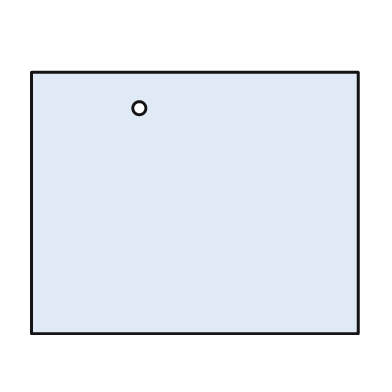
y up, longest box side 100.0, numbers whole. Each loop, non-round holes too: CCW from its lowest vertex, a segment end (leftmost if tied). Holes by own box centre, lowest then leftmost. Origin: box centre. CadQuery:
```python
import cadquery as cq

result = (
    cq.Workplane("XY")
    .moveTo(-50.0, -40.0)
    .lineTo(50.0, -40.0)
    .lineTo(50.0, 40.0)
    .lineTo(-50.0, 40.0)
    .close()
    .moveTo(-17.0, 29.0)
    .circle(2.0)
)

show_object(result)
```